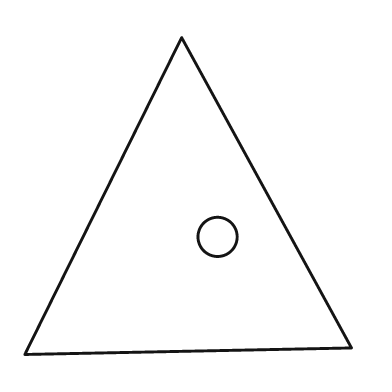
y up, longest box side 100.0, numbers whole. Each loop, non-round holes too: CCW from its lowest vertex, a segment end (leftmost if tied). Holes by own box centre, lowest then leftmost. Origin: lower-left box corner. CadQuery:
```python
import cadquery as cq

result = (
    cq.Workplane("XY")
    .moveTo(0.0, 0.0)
    .lineTo(100.0, 2.0)
    .lineTo(48.0, 97.0)
    .close()
    .moveTo(59.0, 36.0)
    .circle(6.0)
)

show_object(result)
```